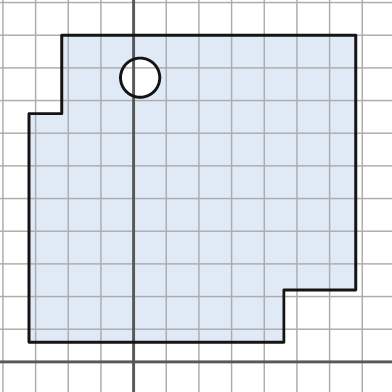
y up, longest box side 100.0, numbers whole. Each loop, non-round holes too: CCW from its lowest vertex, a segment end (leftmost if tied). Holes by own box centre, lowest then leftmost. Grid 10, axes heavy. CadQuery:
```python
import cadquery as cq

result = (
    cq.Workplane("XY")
    .moveTo(-32.0, 6.0)
    .lineTo(46.0, 6.0)
    .lineTo(46.0, 22.0)
    .lineTo(68.0, 22.0)
    .lineTo(68.0, 100.0)
    .lineTo(-22.0, 100.0)
    .lineTo(-22.0, 76.0)
    .lineTo(-32.0, 76.0)
    .close()
    .moveTo(2.0, 87.0)
    .circle(6.0)
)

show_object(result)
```